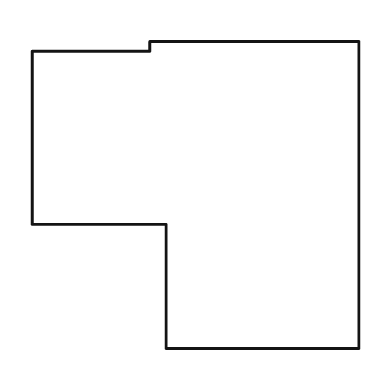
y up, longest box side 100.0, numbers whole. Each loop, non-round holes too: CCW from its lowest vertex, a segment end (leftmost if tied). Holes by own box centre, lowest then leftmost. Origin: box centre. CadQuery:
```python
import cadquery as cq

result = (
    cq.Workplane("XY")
    .moveTo(-9.0, -47.0)
    .lineTo(50.0, -47.0)
    .lineTo(50.0, 47.0)
    .lineTo(-14.0, 47.0)
    .lineTo(-14.0, 44.0)
    .lineTo(-50.0, 44.0)
    .lineTo(-50.0, -9.0)
    .lineTo(-9.0, -9.0)
    .close()
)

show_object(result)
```